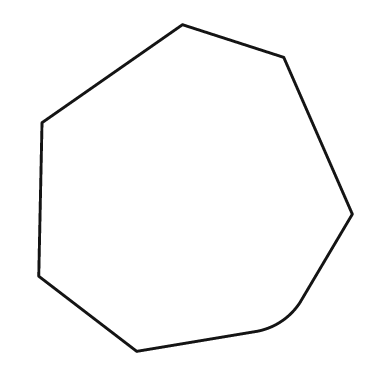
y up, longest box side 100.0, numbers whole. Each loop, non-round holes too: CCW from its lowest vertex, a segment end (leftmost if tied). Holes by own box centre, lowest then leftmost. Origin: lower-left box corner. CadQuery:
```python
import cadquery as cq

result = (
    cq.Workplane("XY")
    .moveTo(30.0, 0.0)
    .lineTo(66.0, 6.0)
    .threePointArc((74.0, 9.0), (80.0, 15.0))
    .lineTo(96.0, 42.0)
    .lineTo(75.0, 90.0)
    .lineTo(44.0, 100.0)
    .lineTo(1.0, 70.0)
    .lineTo(0.0, 23.0)
    .close()
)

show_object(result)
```